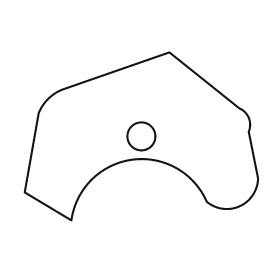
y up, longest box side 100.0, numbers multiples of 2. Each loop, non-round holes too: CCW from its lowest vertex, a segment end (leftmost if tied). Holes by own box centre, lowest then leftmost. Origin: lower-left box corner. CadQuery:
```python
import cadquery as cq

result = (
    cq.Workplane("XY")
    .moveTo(20.0, 0.0)
    .threePointArc((46.0, 26.0), (78.0, 8.0))
    .threePointArc((92.0, 6.0), (100.0, 18.0))
    .lineTo(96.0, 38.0)
    .threePointArc((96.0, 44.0), (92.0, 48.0))
    .lineTo(62.0, 72.0)
    .lineTo(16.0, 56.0)
    .threePointArc((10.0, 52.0), (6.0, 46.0))
    .lineTo(0.0, 12.0)
    .close()
    .moveTo(50.0, 36.0)
    .circle(6.0)
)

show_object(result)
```